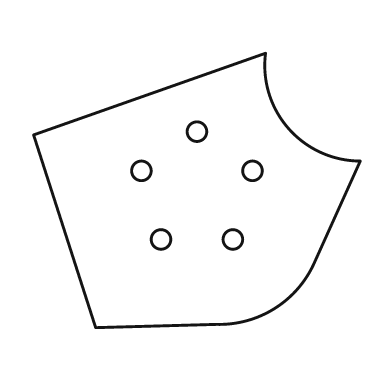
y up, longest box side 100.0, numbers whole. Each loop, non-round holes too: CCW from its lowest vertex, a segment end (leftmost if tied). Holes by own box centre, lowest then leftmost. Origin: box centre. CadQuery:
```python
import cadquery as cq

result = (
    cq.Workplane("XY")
    .moveTo(-31.0, -42.0)
    .lineTo(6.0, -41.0)
    .threePointArc((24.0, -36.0), (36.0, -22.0))
    .lineTo(50.0, 9.0)
    .threePointArc((28.0, 19.0), (21.0, 42.0))
    .lineTo(-50.0, 17.0)
    .close()
    .moveTo(-11.0, -15.0)
    .circle(3.0)
    .moveTo(11.0, -15.0)
    .circle(3.0)
    .moveTo(-17.0, 6.0)
    .circle(3.0)
    .moveTo(17.0, 6.0)
    .circle(3.0)
    .moveTo(0.0, 18.0)
    .circle(3.0)
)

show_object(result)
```